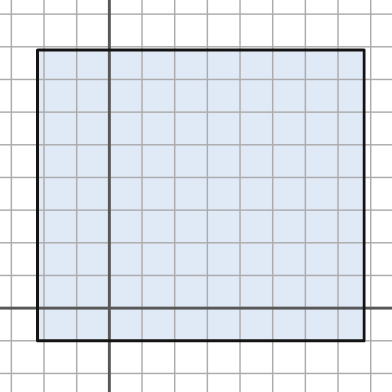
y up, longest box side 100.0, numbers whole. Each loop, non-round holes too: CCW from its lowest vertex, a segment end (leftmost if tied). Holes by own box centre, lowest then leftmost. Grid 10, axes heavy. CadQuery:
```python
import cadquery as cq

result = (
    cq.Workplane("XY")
    .moveTo(-22.0, -10.0)
    .lineTo(78.0, -10.0)
    .lineTo(78.0, 79.0)
    .lineTo(-22.0, 79.0)
    .close()
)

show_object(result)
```